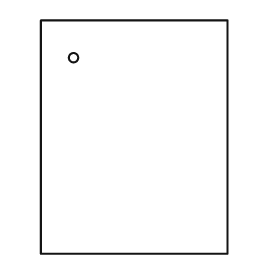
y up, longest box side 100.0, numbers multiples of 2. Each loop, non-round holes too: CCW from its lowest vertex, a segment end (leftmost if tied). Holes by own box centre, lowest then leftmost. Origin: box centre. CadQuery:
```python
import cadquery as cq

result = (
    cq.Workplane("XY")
    .moveTo(-40.0, -50.0)
    .lineTo(40.0, -50.0)
    .lineTo(40.0, 50.0)
    .lineTo(-40.0, 50.0)
    .close()
    .moveTo(-26.0, 34.0)
    .circle(2.0)
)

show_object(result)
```